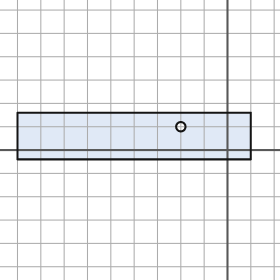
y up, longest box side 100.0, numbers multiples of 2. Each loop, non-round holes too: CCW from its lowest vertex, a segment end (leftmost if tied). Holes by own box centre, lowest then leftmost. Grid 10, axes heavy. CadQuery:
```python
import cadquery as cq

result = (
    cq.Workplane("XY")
    .moveTo(-90.0, -4.0)
    .lineTo(10.0, -4.0)
    .lineTo(10.0, 16.0)
    .lineTo(-90.0, 16.0)
    .close()
    .moveTo(-20.0, 10.0)
    .circle(2.0)
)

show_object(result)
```